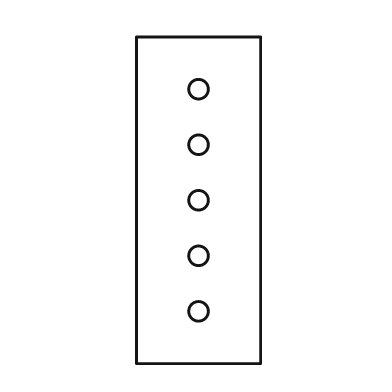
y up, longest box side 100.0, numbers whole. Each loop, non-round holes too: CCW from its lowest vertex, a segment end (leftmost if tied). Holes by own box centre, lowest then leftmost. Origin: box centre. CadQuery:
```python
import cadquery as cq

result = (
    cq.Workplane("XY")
    .moveTo(-19.0, -50.0)
    .lineTo(19.0, -50.0)
    .lineTo(19.0, 50.0)
    .lineTo(-19.0, 50.0)
    .close()
    .moveTo(0.0, -34.0)
    .circle(3.0)
    .moveTo(0.0, -17.0)
    .circle(3.0)
    .moveTo(0.0, 0.0)
    .circle(3.0)
    .moveTo(0.0, 17.0)
    .circle(3.0)
    .moveTo(0.0, 34.0)
    .circle(3.0)
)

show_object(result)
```